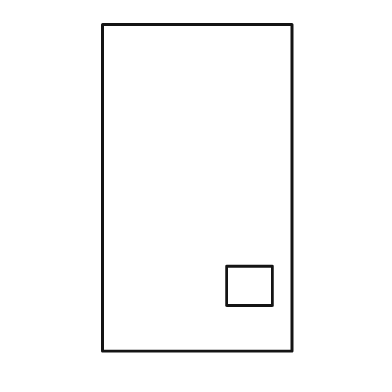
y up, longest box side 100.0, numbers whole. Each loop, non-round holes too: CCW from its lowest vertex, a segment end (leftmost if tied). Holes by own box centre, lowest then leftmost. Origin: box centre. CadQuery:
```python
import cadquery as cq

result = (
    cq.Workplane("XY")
    .moveTo(-29.0, -50.0)
    .lineTo(29.0, -50.0)
    .lineTo(29.0, 50.0)
    .lineTo(-29.0, 50.0)
    .close()
    .moveTo(9.0, -36.0)
    .lineTo(23.0, -36.0)
    .lineTo(23.0, -24.0)
    .lineTo(9.0, -24.0)
    .close()
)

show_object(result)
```